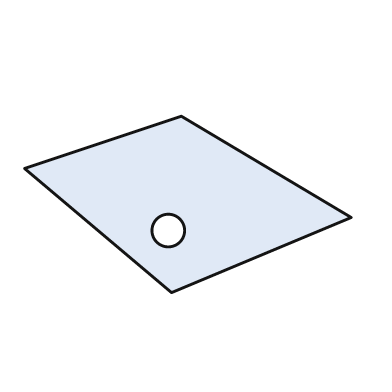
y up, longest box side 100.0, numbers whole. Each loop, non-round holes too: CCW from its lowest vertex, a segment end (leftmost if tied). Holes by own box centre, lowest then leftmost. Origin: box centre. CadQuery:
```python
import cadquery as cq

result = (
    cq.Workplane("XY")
    .moveTo(-5.0, -27.0)
    .lineTo(50.0, -4.0)
    .lineTo(-2.0, 27.0)
    .lineTo(-50.0, 11.0)
    .close()
    .moveTo(-6.0, -8.0)
    .circle(5.0)
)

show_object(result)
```